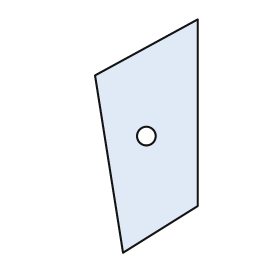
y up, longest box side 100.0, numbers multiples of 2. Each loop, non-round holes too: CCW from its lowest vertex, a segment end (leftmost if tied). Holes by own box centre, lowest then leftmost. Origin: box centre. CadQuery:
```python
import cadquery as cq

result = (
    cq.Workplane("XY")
    .moveTo(-10.0, -50.0)
    .lineTo(22.0, -30.0)
    .lineTo(22.0, 50.0)
    .lineTo(-22.0, 26.0)
    .close()
    .moveTo(0.0, 0.0)
    .circle(4.0)
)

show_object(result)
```